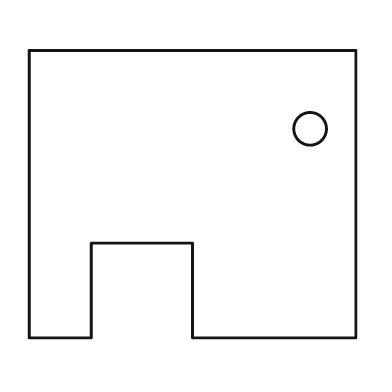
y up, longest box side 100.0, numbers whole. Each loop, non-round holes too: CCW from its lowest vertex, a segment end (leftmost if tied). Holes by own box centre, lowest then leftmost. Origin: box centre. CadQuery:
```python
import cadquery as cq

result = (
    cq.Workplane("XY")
    .moveTo(-50.0, -44.0)
    .lineTo(-31.0, -44.0)
    .lineTo(-31.0, -15.0)
    .lineTo(0.0, -15.0)
    .lineTo(0.0, -44.0)
    .lineTo(50.0, -44.0)
    .lineTo(50.0, 44.0)
    .lineTo(-50.0, 44.0)
    .close()
    .moveTo(36.0, 20.0)
    .circle(5.0)
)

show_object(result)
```